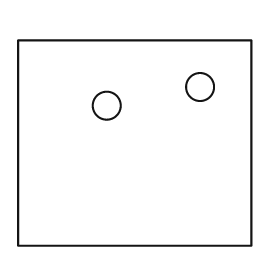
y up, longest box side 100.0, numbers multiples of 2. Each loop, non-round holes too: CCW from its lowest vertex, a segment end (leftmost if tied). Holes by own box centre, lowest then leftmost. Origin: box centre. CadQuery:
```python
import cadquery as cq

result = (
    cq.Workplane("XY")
    .moveTo(-50.0, -44.0)
    .lineTo(50.0, -44.0)
    .lineTo(50.0, 44.0)
    .lineTo(-50.0, 44.0)
    .close()
    .moveTo(-12.0, 16.0)
    .circle(6.0)
    .moveTo(28.0, 24.0)
    .circle(6.0)
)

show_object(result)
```